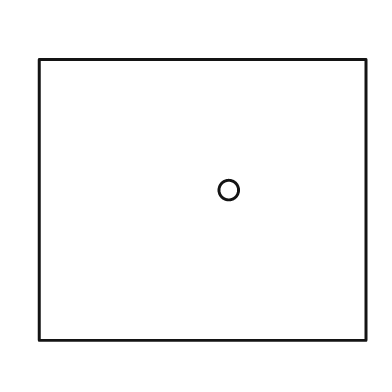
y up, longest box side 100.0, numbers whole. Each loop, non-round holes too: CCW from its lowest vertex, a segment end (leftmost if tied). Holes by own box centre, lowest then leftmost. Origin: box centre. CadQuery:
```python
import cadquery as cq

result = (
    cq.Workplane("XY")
    .moveTo(-50.0, -43.0)
    .lineTo(50.0, -43.0)
    .lineTo(50.0, 43.0)
    .lineTo(-50.0, 43.0)
    .close()
    .moveTo(8.0, 3.0)
    .circle(3.0)
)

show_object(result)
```